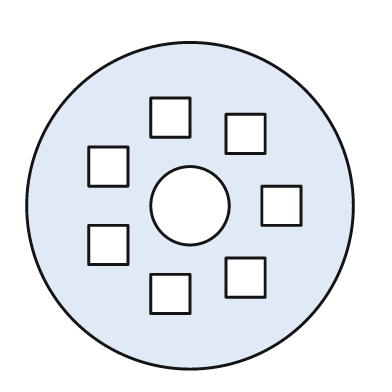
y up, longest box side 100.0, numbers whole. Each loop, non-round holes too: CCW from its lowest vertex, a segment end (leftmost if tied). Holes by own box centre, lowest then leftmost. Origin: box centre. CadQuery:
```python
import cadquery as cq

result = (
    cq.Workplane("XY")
    .moveTo(0.0, 0.0)
    .circle(50.0)
    .moveTo(-12.0, -33.0)
    .lineTo(0.0, -33.0)
    .lineTo(0.0, -21.0)
    .lineTo(-12.0, -21.0)
    .close()
    .moveTo(11.0, -28.0)
    .lineTo(23.0, -28.0)
    .lineTo(23.0, -16.0)
    .lineTo(11.0, -16.0)
    .close()
    .moveTo(-31.0, -18.0)
    .lineTo(-19.0, -18.0)
    .lineTo(-19.0, -6.0)
    .lineTo(-31.0, -6.0)
    .close()
    .moveTo(0.0, 0.0)
    .circle(12.0)
    .moveTo(22.0, -6.0)
    .lineTo(34.0, -6.0)
    .lineTo(34.0, 6.0)
    .lineTo(22.0, 6.0)
    .close()
    .moveTo(-31.0, 6.0)
    .lineTo(-19.0, 6.0)
    .lineTo(-19.0, 18.0)
    .lineTo(-31.0, 18.0)
    .close()
    .moveTo(11.0, 16.0)
    .lineTo(23.0, 16.0)
    .lineTo(23.0, 28.0)
    .lineTo(11.0, 28.0)
    .close()
    .moveTo(-12.0, 21.0)
    .lineTo(0.0, 21.0)
    .lineTo(0.0, 33.0)
    .lineTo(-12.0, 33.0)
    .close()
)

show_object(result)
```